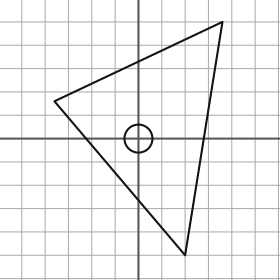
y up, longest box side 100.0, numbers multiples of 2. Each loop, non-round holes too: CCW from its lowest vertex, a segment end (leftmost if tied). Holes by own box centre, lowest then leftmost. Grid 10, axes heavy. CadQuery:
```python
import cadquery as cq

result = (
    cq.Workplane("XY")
    .moveTo(20.0, -50.0)
    .lineTo(36.0, 50.0)
    .lineTo(-36.0, 16.0)
    .close()
    .moveTo(0.0, 0.0)
    .circle(6.0)
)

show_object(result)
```